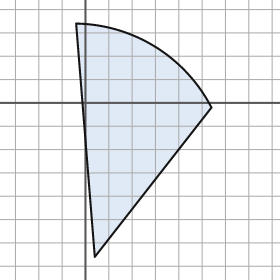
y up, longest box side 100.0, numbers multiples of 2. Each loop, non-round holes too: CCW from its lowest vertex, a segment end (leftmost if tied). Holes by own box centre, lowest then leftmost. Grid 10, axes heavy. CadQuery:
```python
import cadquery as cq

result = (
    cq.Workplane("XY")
    .moveTo(4.0, -66.0)
    .lineTo(54.0, -2.0)
    .threePointArc((30.0, 24.0), (-4.0, 34.0))
    .close()
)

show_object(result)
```